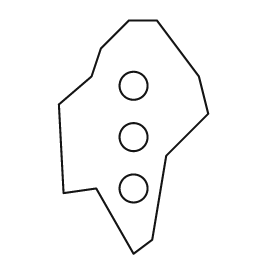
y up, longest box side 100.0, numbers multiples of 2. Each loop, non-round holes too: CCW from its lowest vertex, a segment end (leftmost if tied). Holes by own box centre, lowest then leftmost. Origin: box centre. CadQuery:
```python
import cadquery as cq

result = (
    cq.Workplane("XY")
    .moveTo(0.0, -50.0)
    .lineTo(8.0, -44.0)
    .lineTo(14.0, -8.0)
    .lineTo(32.0, 10.0)
    .lineTo(28.0, 26.0)
    .lineTo(10.0, 50.0)
    .lineTo(-2.0, 50.0)
    .lineTo(-14.0, 38.0)
    .lineTo(-18.0, 26.0)
    .lineTo(-32.0, 14.0)
    .lineTo(-30.0, -24.0)
    .lineTo(-16.0, -22.0)
    .close()
    .moveTo(0.0, -22.0)
    .circle(6.0)
    .moveTo(0.0, 0.0)
    .circle(6.0)
    .moveTo(0.0, 22.0)
    .circle(6.0)
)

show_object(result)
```